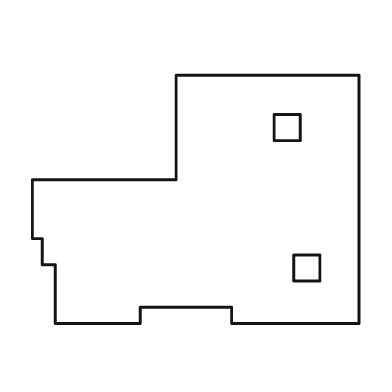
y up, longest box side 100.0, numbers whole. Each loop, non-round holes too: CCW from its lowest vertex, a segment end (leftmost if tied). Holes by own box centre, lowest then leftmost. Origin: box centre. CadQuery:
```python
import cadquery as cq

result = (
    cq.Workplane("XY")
    .moveTo(-43.0, -38.0)
    .lineTo(-17.0, -38.0)
    .lineTo(-17.0, -33.0)
    .lineTo(11.0, -33.0)
    .lineTo(11.0, -38.0)
    .lineTo(50.0, -38.0)
    .lineTo(50.0, 38.0)
    .lineTo(-6.0, 38.0)
    .lineTo(-6.0, 6.0)
    .lineTo(-50.0, 6.0)
    .lineTo(-50.0, -12.0)
    .lineTo(-47.0, -12.0)
    .lineTo(-47.0, -20.0)
    .lineTo(-43.0, -20.0)
    .close()
    .moveTo(30.0, -25.0)
    .lineTo(38.0, -25.0)
    .lineTo(38.0, -17.0)
    .lineTo(30.0, -17.0)
    .close()
    .moveTo(24.0, 18.0)
    .lineTo(32.0, 18.0)
    .lineTo(32.0, 26.0)
    .lineTo(24.0, 26.0)
    .close()
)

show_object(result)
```